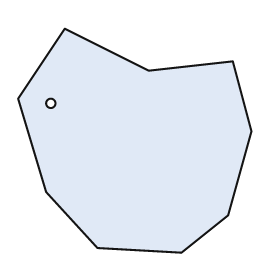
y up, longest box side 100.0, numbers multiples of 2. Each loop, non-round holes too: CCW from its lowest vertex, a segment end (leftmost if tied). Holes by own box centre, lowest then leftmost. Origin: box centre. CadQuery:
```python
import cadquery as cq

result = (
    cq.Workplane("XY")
    .moveTo(20.0, -48.0)
    .lineTo(40.0, -32.0)
    .lineTo(50.0, 4.0)
    .lineTo(42.0, 34.0)
    .lineTo(6.0, 30.0)
    .lineTo(-30.0, 48.0)
    .lineTo(-50.0, 18.0)
    .lineTo(-38.0, -22.0)
    .lineTo(-16.0, -46.0)
    .close()
    .moveTo(-36.0, 16.0)
    .circle(2.0)
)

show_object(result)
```